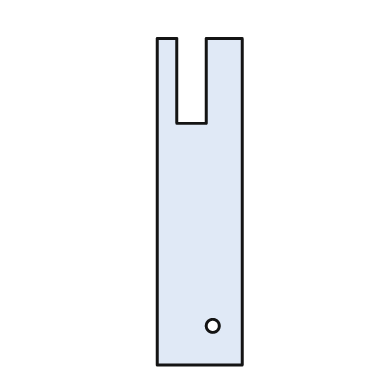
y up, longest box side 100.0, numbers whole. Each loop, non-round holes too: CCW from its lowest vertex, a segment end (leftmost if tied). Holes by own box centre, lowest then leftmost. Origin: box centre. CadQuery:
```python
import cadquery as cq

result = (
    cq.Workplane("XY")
    .moveTo(-13.0, -50.0)
    .lineTo(13.0, -50.0)
    .lineTo(13.0, 50.0)
    .lineTo(2.0, 50.0)
    .lineTo(2.0, 24.0)
    .lineTo(-7.0, 24.0)
    .lineTo(-7.0, 50.0)
    .lineTo(-13.0, 50.0)
    .close()
    .moveTo(4.0, -38.0)
    .circle(2.0)
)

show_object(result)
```